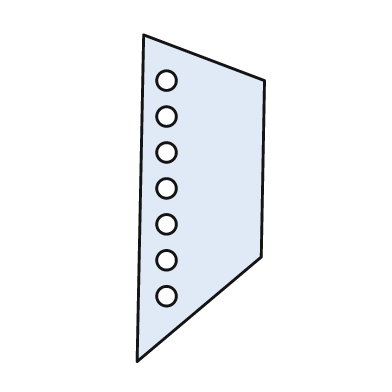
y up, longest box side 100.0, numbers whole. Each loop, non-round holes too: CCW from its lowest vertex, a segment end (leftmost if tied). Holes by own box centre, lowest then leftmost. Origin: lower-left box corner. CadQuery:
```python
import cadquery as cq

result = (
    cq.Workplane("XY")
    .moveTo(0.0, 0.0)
    .lineTo(38.0, 32.0)
    .lineTo(39.0, 86.0)
    .lineTo(2.0, 100.0)
    .close()
    .moveTo(9.0, 20.0)
    .circle(3.0)
    .moveTo(9.0, 31.0)
    .circle(3.0)
    .moveTo(9.0, 42.0)
    .circle(3.0)
    .moveTo(9.0, 53.0)
    .circle(3.0)
    .moveTo(9.0, 64.0)
    .circle(3.0)
    .moveTo(9.0, 75.0)
    .circle(3.0)
    .moveTo(9.0, 86.0)
    .circle(3.0)
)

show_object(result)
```